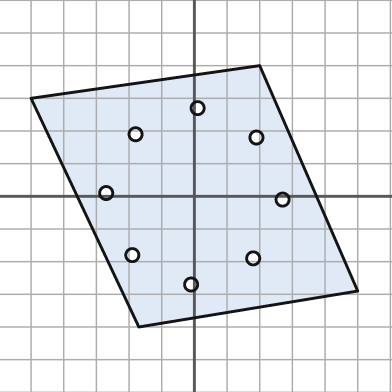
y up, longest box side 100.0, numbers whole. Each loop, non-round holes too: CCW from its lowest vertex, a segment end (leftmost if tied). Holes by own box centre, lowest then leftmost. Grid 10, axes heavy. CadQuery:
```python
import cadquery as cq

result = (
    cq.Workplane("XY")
    .moveTo(-17.0, -40.0)
    .lineTo(50.0, -29.0)
    .lineTo(20.0, 40.0)
    .lineTo(-50.0, 30.0)
    .close()
    .moveTo(-1.0, -27.0)
    .circle(2.0)
    .moveTo(18.0, -19.0)
    .circle(2.0)
    .moveTo(-19.0, -18.0)
    .circle(2.0)
    .moveTo(27.0, -1.0)
    .circle(2.0)
    .moveTo(-27.0, 1.0)
    .circle(2.0)
    .moveTo(19.0, 18.0)
    .circle(2.0)
    .moveTo(-18.0, 19.0)
    .circle(2.0)
    .moveTo(1.0, 27.0)
    .circle(2.0)
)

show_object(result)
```